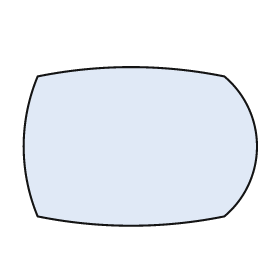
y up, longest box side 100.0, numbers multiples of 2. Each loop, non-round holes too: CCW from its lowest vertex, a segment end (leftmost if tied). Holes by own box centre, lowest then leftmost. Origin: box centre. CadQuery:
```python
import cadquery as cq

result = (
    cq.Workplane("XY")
    .moveTo(-44.0, -30.0)
    .threePointArc((-4.0, -34.0), (36.0, -30.0))
    .threePointArc((50.0, 0.0), (36.0, 30.0))
    .threePointArc((-4.0, 34.0), (-44.0, 30.0))
    .threePointArc((-50.0, 0.0), (-44.0, -30.0))
    .close()
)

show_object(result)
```